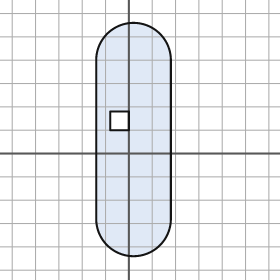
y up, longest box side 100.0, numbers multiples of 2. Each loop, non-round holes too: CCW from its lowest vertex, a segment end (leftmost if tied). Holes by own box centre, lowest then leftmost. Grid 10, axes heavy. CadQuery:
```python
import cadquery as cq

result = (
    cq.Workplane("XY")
    .moveTo(-14.0, -28.0)
    .threePointArc((2.0, -44.0), (18.0, -28.0))
    .lineTo(18.0, 40.0)
    .threePointArc((2.0, 56.0), (-14.0, 40.0))
    .close()
    .moveTo(-8.0, 10.0)
    .lineTo(0.0, 10.0)
    .lineTo(0.0, 18.0)
    .lineTo(-8.0, 18.0)
    .close()
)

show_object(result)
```